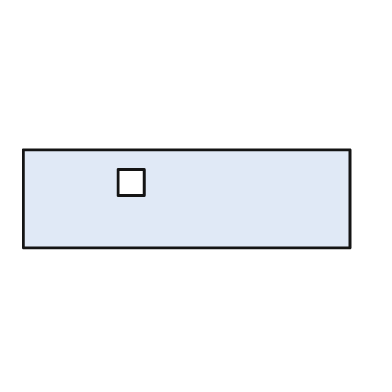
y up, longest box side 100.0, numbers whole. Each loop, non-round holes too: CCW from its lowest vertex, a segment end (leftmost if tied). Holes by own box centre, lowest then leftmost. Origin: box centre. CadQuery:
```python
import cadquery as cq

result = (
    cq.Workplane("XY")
    .moveTo(-50.0, -15.0)
    .lineTo(50.0, -15.0)
    .lineTo(50.0, 15.0)
    .lineTo(-50.0, 15.0)
    .close()
    .moveTo(-21.0, 1.0)
    .lineTo(-13.0, 1.0)
    .lineTo(-13.0, 9.0)
    .lineTo(-21.0, 9.0)
    .close()
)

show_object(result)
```